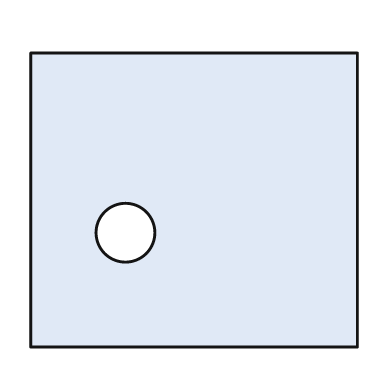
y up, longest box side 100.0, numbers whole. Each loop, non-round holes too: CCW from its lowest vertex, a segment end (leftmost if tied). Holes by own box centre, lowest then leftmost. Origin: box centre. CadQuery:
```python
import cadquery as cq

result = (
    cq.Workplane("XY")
    .moveTo(-50.0, -45.0)
    .lineTo(50.0, -45.0)
    .lineTo(50.0, 45.0)
    .lineTo(-50.0, 45.0)
    .close()
    .moveTo(-21.0, -10.0)
    .circle(9.0)
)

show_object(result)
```